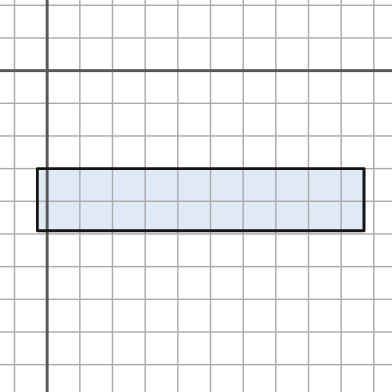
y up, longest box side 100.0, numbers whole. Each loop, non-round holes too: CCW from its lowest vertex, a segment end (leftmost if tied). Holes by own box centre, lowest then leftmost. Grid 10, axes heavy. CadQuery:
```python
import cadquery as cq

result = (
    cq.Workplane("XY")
    .moveTo(-3.0, -49.0)
    .lineTo(97.0, -49.0)
    .lineTo(97.0, -30.0)
    .lineTo(-3.0, -30.0)
    .close()
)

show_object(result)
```